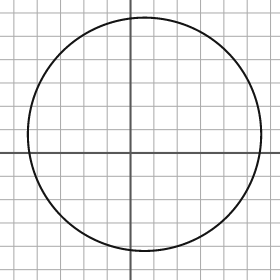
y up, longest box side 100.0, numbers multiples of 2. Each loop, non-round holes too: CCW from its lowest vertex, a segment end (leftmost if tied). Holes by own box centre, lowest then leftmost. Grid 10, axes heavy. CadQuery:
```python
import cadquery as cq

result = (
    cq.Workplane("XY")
    .moveTo(6.0, 8.0)
    .circle(50.0)
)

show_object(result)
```